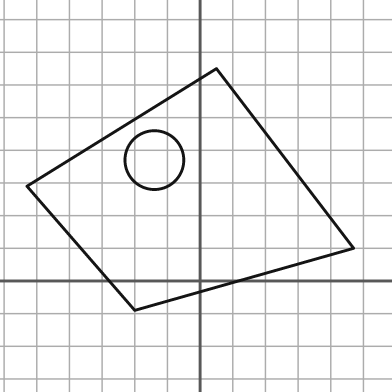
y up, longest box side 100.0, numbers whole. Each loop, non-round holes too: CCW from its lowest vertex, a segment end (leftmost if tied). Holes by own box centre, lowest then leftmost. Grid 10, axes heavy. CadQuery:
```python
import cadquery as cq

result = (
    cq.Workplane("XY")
    .moveTo(-20.0, -9.0)
    .lineTo(47.0, 10.0)
    .lineTo(5.0, 65.0)
    .lineTo(-53.0, 29.0)
    .close()
    .moveTo(-14.0, 37.0)
    .circle(9.0)
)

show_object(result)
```